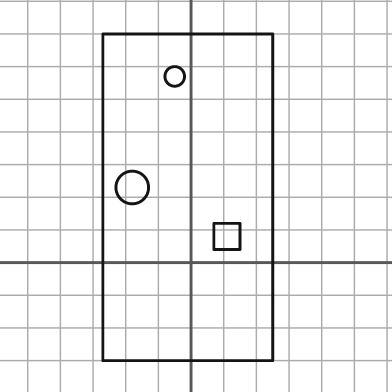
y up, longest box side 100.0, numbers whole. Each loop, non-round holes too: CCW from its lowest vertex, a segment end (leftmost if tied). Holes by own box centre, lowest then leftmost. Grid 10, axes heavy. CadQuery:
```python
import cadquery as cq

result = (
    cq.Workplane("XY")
    .moveTo(-27.0, -30.0)
    .lineTo(25.0, -30.0)
    .lineTo(25.0, 70.0)
    .lineTo(-27.0, 70.0)
    .close()
    .moveTo(7.0, 4.0)
    .lineTo(15.0, 4.0)
    .lineTo(15.0, 12.0)
    .lineTo(7.0, 12.0)
    .close()
    .moveTo(-18.0, 23.0)
    .circle(5.0)
    .moveTo(-5.0, 57.0)
    .circle(3.0)
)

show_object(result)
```